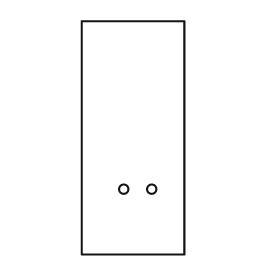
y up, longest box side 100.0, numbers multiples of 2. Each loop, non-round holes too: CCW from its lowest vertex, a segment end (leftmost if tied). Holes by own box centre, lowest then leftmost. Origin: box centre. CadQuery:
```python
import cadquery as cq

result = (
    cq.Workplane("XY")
    .moveTo(-22.0, -50.0)
    .lineTo(22.0, -50.0)
    .lineTo(22.0, 50.0)
    .lineTo(-22.0, 50.0)
    .close()
    .moveTo(-4.0, -22.0)
    .circle(2.0)
    .moveTo(8.0, -22.0)
    .circle(2.0)
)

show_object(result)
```